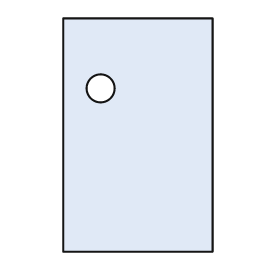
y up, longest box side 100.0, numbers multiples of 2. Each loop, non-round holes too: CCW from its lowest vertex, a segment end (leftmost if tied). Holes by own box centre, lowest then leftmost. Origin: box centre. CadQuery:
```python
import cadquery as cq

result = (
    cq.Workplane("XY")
    .moveTo(-32.0, -50.0)
    .lineTo(32.0, -50.0)
    .lineTo(32.0, 50.0)
    .lineTo(-32.0, 50.0)
    .close()
    .moveTo(-16.0, 20.0)
    .circle(6.0)
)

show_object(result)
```